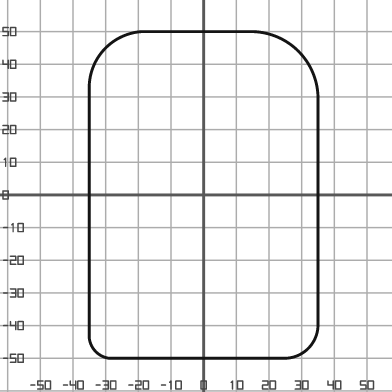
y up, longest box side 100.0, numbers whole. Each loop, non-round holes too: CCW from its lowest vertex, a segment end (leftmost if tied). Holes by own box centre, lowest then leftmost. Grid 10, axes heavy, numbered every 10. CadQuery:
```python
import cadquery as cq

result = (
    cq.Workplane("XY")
    .moveTo(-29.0, -50.0)
    .lineTo(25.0, -50.0)
    .threePointArc((32.0, -47.0), (35.0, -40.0))
    .lineTo(35.0, 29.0)
    .threePointArc((29.0, 44.0), (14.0, 50.0))
    .lineTo(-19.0, 50.0)
    .threePointArc((-30.0, 45.0), (-35.0, 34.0))
    .lineTo(-35.0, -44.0)
    .threePointArc((-33.0, -48.0), (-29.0, -50.0))
    .close()
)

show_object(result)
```